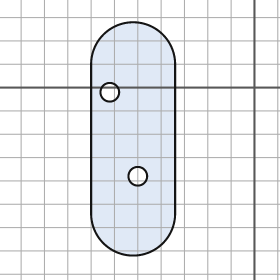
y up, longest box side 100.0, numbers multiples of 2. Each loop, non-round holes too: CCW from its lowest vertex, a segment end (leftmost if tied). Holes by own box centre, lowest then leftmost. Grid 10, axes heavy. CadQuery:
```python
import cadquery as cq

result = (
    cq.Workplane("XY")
    .moveTo(-70.0, -54.0)
    .threePointArc((-52.0, -72.0), (-34.0, -54.0))
    .lineTo(-34.0, 10.0)
    .threePointArc((-52.0, 28.0), (-70.0, 10.0))
    .close()
    .moveTo(-50.0, -38.0)
    .circle(4.0)
    .moveTo(-62.0, -2.0)
    .circle(4.0)
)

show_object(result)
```